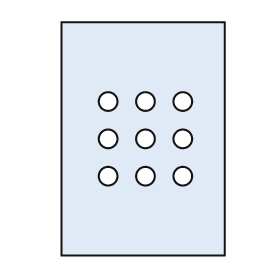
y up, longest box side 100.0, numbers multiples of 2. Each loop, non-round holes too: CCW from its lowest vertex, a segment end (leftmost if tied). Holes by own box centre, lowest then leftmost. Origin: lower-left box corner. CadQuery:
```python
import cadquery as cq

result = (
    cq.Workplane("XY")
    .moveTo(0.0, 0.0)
    .lineTo(70.0, 0.0)
    .lineTo(70.0, 100.0)
    .lineTo(0.0, 100.0)
    .close()
    .moveTo(20.0, 34.0)
    .circle(4.0)
    .moveTo(36.0, 34.0)
    .circle(4.0)
    .moveTo(52.0, 34.0)
    .circle(4.0)
    .moveTo(20.0, 50.0)
    .circle(4.0)
    .moveTo(36.0, 50.0)
    .circle(4.0)
    .moveTo(52.0, 50.0)
    .circle(4.0)
    .moveTo(20.0, 66.0)
    .circle(4.0)
    .moveTo(36.0, 66.0)
    .circle(4.0)
    .moveTo(52.0, 66.0)
    .circle(4.0)
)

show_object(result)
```